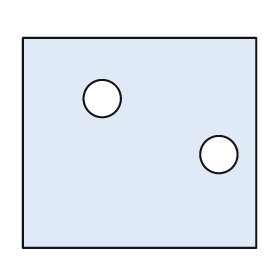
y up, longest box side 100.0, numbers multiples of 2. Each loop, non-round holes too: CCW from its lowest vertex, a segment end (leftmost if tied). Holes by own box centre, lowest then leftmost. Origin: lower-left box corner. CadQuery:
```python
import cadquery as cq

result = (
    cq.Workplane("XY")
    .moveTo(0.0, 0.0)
    .lineTo(100.0, 0.0)
    .lineTo(100.0, 90.0)
    .lineTo(0.0, 90.0)
    .close()
    .moveTo(84.0, 40.0)
    .circle(8.0)
    .moveTo(34.0, 64.0)
    .circle(8.0)
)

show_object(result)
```